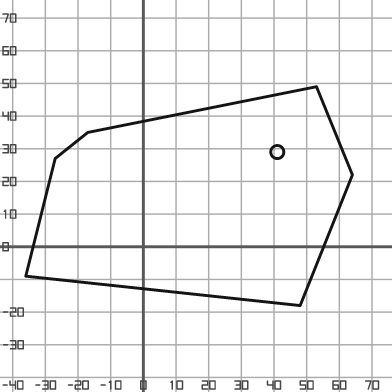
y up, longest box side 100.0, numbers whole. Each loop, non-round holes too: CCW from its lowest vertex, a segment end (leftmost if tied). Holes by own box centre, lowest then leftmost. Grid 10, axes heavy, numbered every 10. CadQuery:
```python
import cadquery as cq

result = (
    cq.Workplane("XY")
    .moveTo(48.0, -18.0)
    .lineTo(64.0, 22.0)
    .lineTo(53.0, 49.0)
    .lineTo(-17.0, 35.0)
    .lineTo(-27.0, 27.0)
    .lineTo(-36.0, -9.0)
    .close()
    .moveTo(41.0, 29.0)
    .circle(2.0)
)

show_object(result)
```